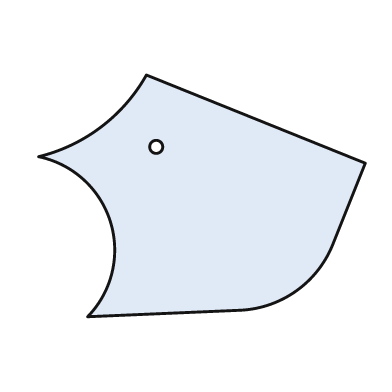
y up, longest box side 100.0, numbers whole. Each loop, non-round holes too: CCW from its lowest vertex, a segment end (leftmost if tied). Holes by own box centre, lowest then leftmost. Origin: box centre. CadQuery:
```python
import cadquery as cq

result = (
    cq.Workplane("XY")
    .moveTo(-35.0, -37.0)
    .lineTo(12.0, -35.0)
    .threePointArc((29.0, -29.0), (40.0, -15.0))
    .lineTo(50.0, 10.0)
    .lineTo(-17.0, 37.0)
    .threePointArc((-31.0, 21.0), (-50.0, 12.0))
    .threePointArc((-28.0, -8.0), (-35.0, -37.0))
    .close()
    .moveTo(-14.0, 15.0)
    .circle(2.0)
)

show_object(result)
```